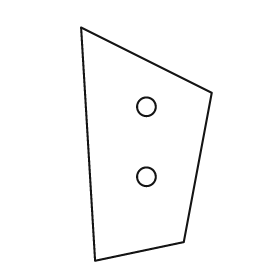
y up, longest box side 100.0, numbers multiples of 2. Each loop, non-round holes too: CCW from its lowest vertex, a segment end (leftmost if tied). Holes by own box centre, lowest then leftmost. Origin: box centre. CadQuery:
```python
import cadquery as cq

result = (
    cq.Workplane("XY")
    .moveTo(-22.0, -50.0)
    .lineTo(16.0, -42.0)
    .lineTo(28.0, 22.0)
    .lineTo(-28.0, 50.0)
    .close()
    .moveTo(0.0, -14.0)
    .circle(4.0)
    .moveTo(0.0, 16.0)
    .circle(4.0)
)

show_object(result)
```